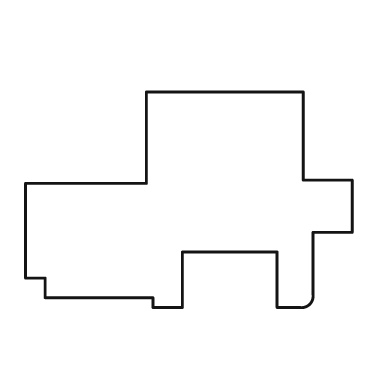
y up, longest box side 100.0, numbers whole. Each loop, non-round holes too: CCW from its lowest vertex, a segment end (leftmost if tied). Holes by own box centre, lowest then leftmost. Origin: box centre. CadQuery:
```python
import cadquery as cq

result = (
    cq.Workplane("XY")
    .moveTo(-11.0, -33.0)
    .lineTo(-2.0, -33.0)
    .lineTo(-2.0, -16.0)
    .lineTo(27.0, -16.0)
    .lineTo(27.0, -33.0)
    .lineTo(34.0, -33.0)
    .threePointArc((37.0, -32.0), (38.0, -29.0))
    .lineTo(38.0, -10.0)
    .lineTo(50.0, -10.0)
    .lineTo(50.0, 6.0)
    .lineTo(35.0, 6.0)
    .lineTo(35.0, 33.0)
    .lineTo(-13.0, 33.0)
    .lineTo(-13.0, 5.0)
    .lineTo(-50.0, 5.0)
    .lineTo(-50.0, -24.0)
    .lineTo(-44.0, -24.0)
    .lineTo(-44.0, -30.0)
    .lineTo(-11.0, -30.0)
    .close()
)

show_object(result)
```